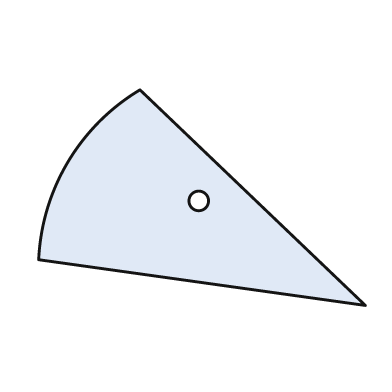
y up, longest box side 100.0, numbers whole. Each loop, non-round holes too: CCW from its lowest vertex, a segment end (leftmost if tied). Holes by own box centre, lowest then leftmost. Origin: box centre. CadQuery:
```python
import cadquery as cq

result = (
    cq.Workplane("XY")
    .moveTo(50.0, -33.0)
    .lineTo(-19.0, 33.0)
    .threePointArc((-41.0, 11.0), (-50.0, -19.0))
    .close()
    .moveTo(-1.0, -1.0)
    .circle(3.0)
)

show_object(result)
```